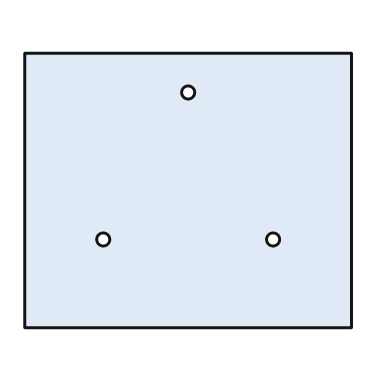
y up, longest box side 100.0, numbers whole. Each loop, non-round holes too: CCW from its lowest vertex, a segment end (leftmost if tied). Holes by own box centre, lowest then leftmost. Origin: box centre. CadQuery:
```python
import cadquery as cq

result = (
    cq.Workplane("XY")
    .moveTo(-50.0, -42.0)
    .lineTo(50.0, -42.0)
    .lineTo(50.0, 42.0)
    .lineTo(-50.0, 42.0)
    .close()
    .moveTo(-26.0, -15.0)
    .circle(2.0)
    .moveTo(26.0, -15.0)
    .circle(2.0)
    .moveTo(0.0, 30.0)
    .circle(2.0)
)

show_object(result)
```